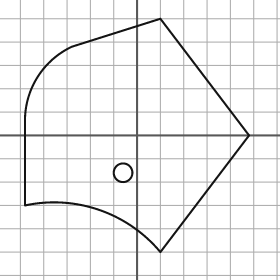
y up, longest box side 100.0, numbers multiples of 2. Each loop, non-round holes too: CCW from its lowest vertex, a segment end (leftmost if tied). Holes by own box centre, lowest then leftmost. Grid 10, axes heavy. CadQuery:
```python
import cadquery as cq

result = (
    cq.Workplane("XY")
    .moveTo(10.0, -50.0)
    .lineTo(48.0, 0.0)
    .lineTo(10.0, 50.0)
    .lineTo(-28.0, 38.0)
    .threePointArc((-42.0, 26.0), (-48.0, 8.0))
    .lineTo(-48.0, -30.0)
    .threePointArc((-16.0, -32.0), (10.0, -50.0))
    .close()
    .moveTo(-6.0, -16.0)
    .circle(4.0)
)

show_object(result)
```